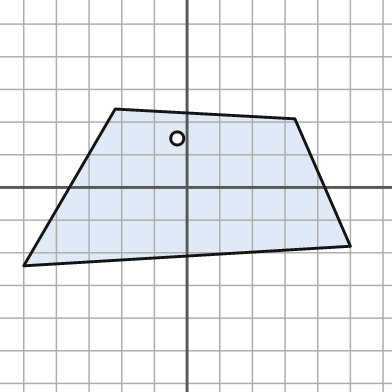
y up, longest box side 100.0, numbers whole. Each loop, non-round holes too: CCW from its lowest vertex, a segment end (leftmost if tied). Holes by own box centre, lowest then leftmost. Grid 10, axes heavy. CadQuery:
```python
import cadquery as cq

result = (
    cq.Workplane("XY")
    .moveTo(-50.0, -24.0)
    .lineTo(50.0, -18.0)
    .lineTo(33.0, 21.0)
    .lineTo(-22.0, 24.0)
    .close()
    .moveTo(-3.0, 15.0)
    .circle(2.0)
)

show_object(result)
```